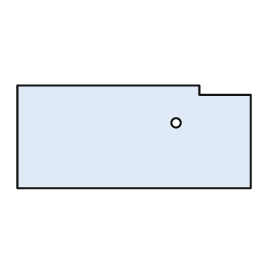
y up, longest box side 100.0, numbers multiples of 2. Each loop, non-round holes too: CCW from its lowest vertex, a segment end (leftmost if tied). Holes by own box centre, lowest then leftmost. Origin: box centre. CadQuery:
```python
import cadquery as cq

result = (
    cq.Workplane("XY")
    .moveTo(-50.0, -22.0)
    .lineTo(50.0, -22.0)
    .lineTo(50.0, 18.0)
    .lineTo(28.0, 18.0)
    .lineTo(28.0, 22.0)
    .lineTo(-50.0, 22.0)
    .close()
    .moveTo(18.0, 6.0)
    .circle(2.0)
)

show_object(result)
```